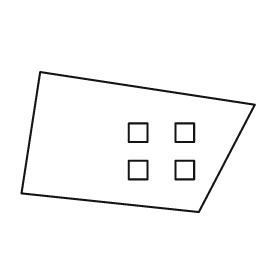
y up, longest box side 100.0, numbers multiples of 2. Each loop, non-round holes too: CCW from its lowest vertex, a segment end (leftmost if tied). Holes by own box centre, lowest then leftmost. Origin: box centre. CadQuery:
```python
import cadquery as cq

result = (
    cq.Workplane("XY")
    .moveTo(26.0, -30.0)
    .lineTo(50.0, 16.0)
    .lineTo(-42.0, 30.0)
    .lineTo(-50.0, -22.0)
    .close()
    .moveTo(-4.0, -16.0)
    .lineTo(4.0, -16.0)
    .lineTo(4.0, -8.0)
    .lineTo(-4.0, -8.0)
    .close()
    .moveTo(16.0, -16.0)
    .lineTo(24.0, -16.0)
    .lineTo(24.0, -8.0)
    .lineTo(16.0, -8.0)
    .close()
    .moveTo(-4.0, 0.0)
    .lineTo(4.0, 0.0)
    .lineTo(4.0, 8.0)
    .lineTo(-4.0, 8.0)
    .close()
    .moveTo(16.0, 0.0)
    .lineTo(24.0, 0.0)
    .lineTo(24.0, 8.0)
    .lineTo(16.0, 8.0)
    .close()
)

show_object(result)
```